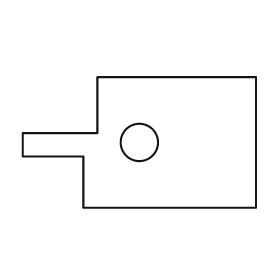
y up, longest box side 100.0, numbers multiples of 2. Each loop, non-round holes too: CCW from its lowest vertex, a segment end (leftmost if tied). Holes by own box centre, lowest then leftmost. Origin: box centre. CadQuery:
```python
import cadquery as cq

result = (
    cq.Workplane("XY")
    .moveTo(-24.0, -28.0)
    .lineTo(50.0, -28.0)
    .lineTo(50.0, 28.0)
    .lineTo(-18.0, 28.0)
    .lineTo(-18.0, 4.0)
    .lineTo(-50.0, 4.0)
    .lineTo(-50.0, -6.0)
    .lineTo(-24.0, -6.0)
    .close()
    .moveTo(0.0, 0.0)
    .circle(8.0)
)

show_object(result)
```